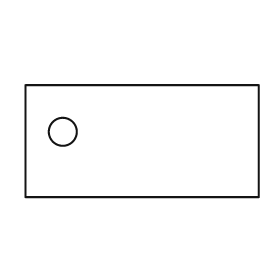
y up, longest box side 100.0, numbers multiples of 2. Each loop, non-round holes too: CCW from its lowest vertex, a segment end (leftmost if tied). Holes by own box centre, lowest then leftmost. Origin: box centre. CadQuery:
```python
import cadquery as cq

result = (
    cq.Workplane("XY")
    .moveTo(-50.0, -24.0)
    .lineTo(50.0, -24.0)
    .lineTo(50.0, 24.0)
    .lineTo(-50.0, 24.0)
    .close()
    .moveTo(-34.0, 4.0)
    .circle(6.0)
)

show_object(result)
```